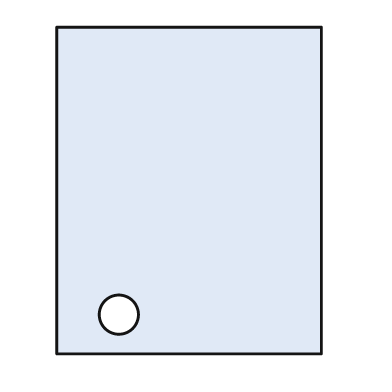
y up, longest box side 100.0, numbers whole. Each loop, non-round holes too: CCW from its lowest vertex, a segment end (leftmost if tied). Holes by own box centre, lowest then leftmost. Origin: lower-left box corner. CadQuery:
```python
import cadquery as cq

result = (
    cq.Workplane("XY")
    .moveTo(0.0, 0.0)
    .lineTo(81.0, 0.0)
    .lineTo(81.0, 100.0)
    .lineTo(0.0, 100.0)
    .close()
    .moveTo(19.0, 12.0)
    .circle(6.0)
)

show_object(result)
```